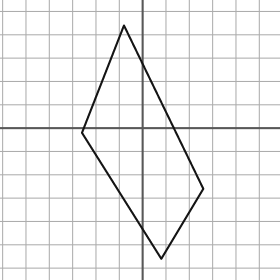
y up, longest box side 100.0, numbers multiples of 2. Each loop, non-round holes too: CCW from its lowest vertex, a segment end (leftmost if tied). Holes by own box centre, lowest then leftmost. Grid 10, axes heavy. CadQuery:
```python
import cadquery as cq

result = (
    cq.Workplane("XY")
    .moveTo(8.0, -56.0)
    .lineTo(26.0, -26.0)
    .lineTo(-8.0, 44.0)
    .lineTo(-26.0, -2.0)
    .close()
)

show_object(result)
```